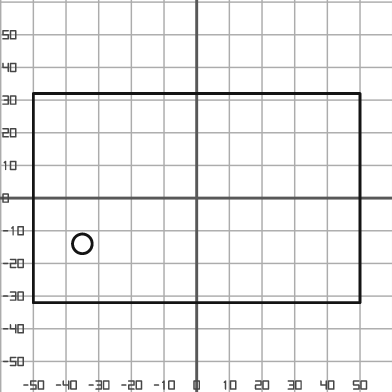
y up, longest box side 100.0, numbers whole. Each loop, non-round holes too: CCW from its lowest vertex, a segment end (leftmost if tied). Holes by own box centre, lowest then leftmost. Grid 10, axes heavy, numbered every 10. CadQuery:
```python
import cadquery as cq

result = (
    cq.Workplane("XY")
    .moveTo(-50.0, -32.0)
    .lineTo(50.0, -32.0)
    .lineTo(50.0, 32.0)
    .lineTo(-50.0, 32.0)
    .close()
    .moveTo(-35.0, -14.0)
    .circle(3.0)
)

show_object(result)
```